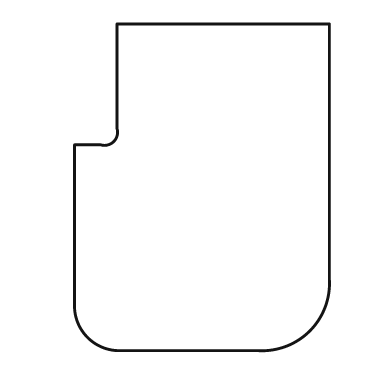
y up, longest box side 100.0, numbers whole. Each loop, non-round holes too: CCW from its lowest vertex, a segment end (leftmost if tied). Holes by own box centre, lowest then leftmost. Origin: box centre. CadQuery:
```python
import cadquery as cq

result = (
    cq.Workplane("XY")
    .moveTo(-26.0, -50.0)
    .lineTo(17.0, -50.0)
    .threePointArc((33.0, -44.0), (39.0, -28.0))
    .lineTo(39.0, 50.0)
    .lineTo(-26.0, 50.0)
    .lineTo(-26.0, 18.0)
    .threePointArc((-27.0, 14.0), (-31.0, 13.0))
    .lineTo(-39.0, 13.0)
    .lineTo(-39.0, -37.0)
    .threePointArc((-35.0, -46.0), (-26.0, -50.0))
    .close()
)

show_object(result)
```